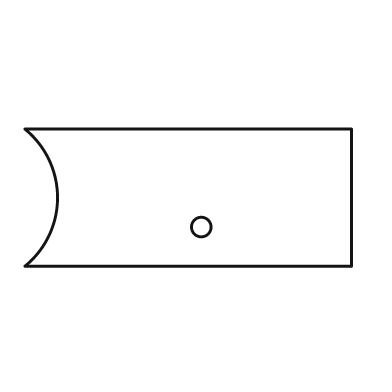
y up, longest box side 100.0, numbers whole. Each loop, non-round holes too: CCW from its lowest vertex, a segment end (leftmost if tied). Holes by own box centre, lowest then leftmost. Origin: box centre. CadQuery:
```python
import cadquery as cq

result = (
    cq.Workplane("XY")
    .moveTo(-50.0, -21.0)
    .lineTo(50.0, -21.0)
    .lineTo(50.0, 21.0)
    .lineTo(-50.0, 21.0)
    .threePointArc((-40.0, 0.0), (-50.0, -21.0))
    .close()
    .moveTo(4.0, -9.0)
    .circle(3.0)
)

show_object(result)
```